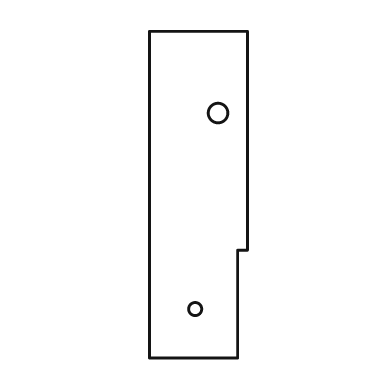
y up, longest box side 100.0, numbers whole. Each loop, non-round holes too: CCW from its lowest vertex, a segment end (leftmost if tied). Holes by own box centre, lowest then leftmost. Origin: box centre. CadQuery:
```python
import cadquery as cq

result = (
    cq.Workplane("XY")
    .moveTo(-15.0, -50.0)
    .lineTo(12.0, -50.0)
    .lineTo(12.0, -17.0)
    .lineTo(15.0, -17.0)
    .lineTo(15.0, 50.0)
    .lineTo(-15.0, 50.0)
    .close()
    .moveTo(-1.0, -35.0)
    .circle(2.0)
    .moveTo(6.0, 25.0)
    .circle(3.0)
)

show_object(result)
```